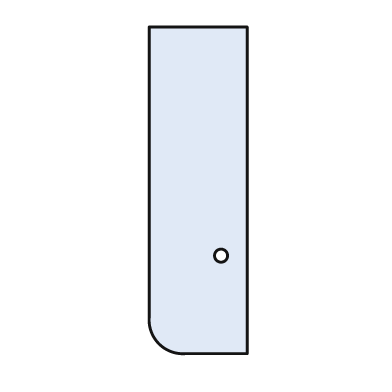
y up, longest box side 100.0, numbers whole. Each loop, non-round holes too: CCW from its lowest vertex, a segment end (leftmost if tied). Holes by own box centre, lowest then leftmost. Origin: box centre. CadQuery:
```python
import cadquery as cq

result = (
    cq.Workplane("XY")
    .moveTo(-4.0, -50.0)
    .lineTo(15.0, -50.0)
    .lineTo(15.0, 50.0)
    .lineTo(-15.0, 50.0)
    .lineTo(-15.0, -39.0)
    .threePointArc((-12.0, -47.0), (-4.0, -50.0))
    .close()
    .moveTo(7.0, -20.0)
    .circle(2.0)
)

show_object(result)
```